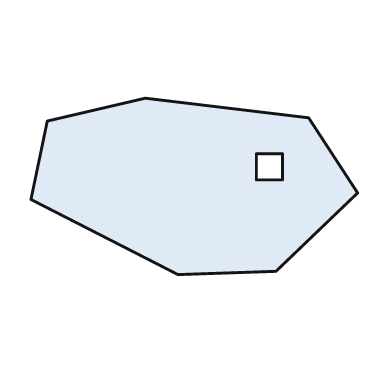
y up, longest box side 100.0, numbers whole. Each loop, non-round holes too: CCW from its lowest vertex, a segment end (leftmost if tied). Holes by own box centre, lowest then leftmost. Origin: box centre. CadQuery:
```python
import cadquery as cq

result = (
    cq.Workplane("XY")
    .moveTo(-5.0, -27.0)
    .lineTo(25.0, -26.0)
    .lineTo(50.0, -2.0)
    .lineTo(35.0, 21.0)
    .lineTo(-15.0, 27.0)
    .lineTo(-45.0, 20.0)
    .lineTo(-50.0, -4.0)
    .close()
    .moveTo(19.0, 2.0)
    .lineTo(27.0, 2.0)
    .lineTo(27.0, 10.0)
    .lineTo(19.0, 10.0)
    .close()
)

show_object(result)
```